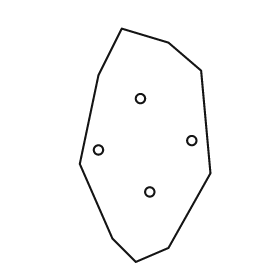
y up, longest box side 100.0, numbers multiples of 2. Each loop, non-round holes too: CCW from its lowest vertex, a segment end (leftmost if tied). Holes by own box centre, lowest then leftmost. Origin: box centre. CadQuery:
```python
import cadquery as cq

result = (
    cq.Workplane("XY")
    .moveTo(-4.0, -50.0)
    .lineTo(10.0, -44.0)
    .lineTo(28.0, -12.0)
    .lineTo(24.0, 32.0)
    .lineTo(10.0, 44.0)
    .lineTo(-10.0, 50.0)
    .lineTo(-20.0, 30.0)
    .lineTo(-28.0, -8.0)
    .lineTo(-14.0, -40.0)
    .close()
    .moveTo(2.0, -20.0)
    .circle(2.0)
    .moveTo(-20.0, -2.0)
    .circle(2.0)
    .moveTo(20.0, 2.0)
    .circle(2.0)
    .moveTo(-2.0, 20.0)
    .circle(2.0)
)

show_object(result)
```